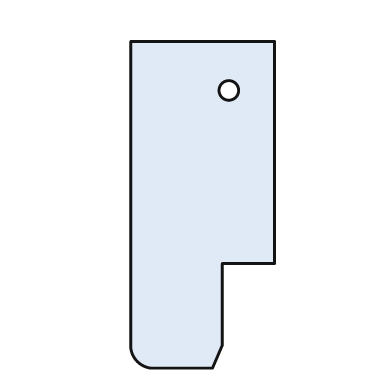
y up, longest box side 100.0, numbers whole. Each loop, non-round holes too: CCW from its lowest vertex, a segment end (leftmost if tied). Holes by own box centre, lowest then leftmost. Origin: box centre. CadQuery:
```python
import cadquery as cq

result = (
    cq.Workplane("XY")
    .moveTo(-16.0, -50.0)
    .lineTo(3.0, -50.0)
    .lineTo(6.0, -43.0)
    .lineTo(6.0, -18.0)
    .lineTo(22.0, -18.0)
    .lineTo(22.0, 50.0)
    .lineTo(-22.0, 50.0)
    .lineTo(-22.0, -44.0)
    .threePointArc((-20.0, -48.0), (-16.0, -50.0))
    .close()
    .moveTo(8.0, 35.0)
    .circle(3.0)
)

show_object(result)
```